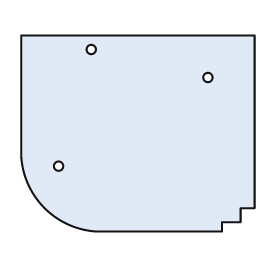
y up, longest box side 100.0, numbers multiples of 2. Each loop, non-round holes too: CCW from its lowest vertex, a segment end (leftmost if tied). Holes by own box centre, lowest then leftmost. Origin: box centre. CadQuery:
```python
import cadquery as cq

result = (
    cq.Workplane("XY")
    .moveTo(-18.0, -42.0)
    .lineTo(36.0, -42.0)
    .lineTo(36.0, -38.0)
    .lineTo(44.0, -38.0)
    .lineTo(44.0, -32.0)
    .lineTo(50.0, -32.0)
    .lineTo(50.0, 42.0)
    .lineTo(-50.0, 42.0)
    .lineTo(-50.0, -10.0)
    .threePointArc((-40.0, -32.0), (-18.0, -42.0))
    .close()
    .moveTo(-34.0, -14.0)
    .circle(2.0)
    .moveTo(30.0, 24.0)
    .circle(2.0)
    .moveTo(-20.0, 36.0)
    .circle(2.0)
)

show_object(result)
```